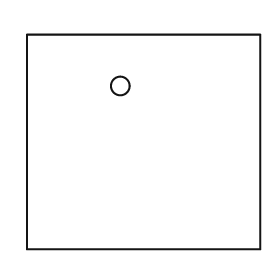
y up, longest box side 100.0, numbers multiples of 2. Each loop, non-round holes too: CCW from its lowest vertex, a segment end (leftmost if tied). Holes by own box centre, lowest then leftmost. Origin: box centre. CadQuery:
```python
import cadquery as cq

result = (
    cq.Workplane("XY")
    .moveTo(-50.0, -46.0)
    .lineTo(50.0, -46.0)
    .lineTo(50.0, 46.0)
    .lineTo(-50.0, 46.0)
    .close()
    .moveTo(-10.0, 24.0)
    .circle(4.0)
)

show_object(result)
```